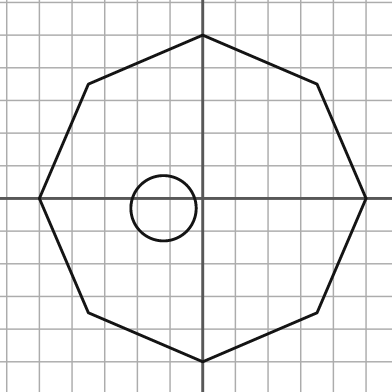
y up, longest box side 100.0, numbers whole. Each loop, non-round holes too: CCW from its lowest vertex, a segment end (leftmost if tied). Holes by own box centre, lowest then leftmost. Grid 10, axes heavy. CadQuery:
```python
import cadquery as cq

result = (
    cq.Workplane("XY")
    .moveTo(0.0, -50.0)
    .lineTo(35.0, -35.0)
    .lineTo(50.0, 0.0)
    .lineTo(35.0, 35.0)
    .lineTo(0.0, 50.0)
    .lineTo(-35.0, 35.0)
    .lineTo(-50.0, 0.0)
    .lineTo(-35.0, -35.0)
    .close()
    .moveTo(-12.0, -3.0)
    .circle(10.0)
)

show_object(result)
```